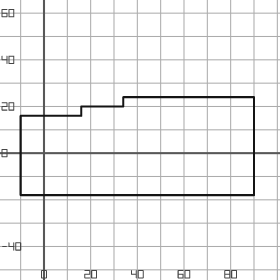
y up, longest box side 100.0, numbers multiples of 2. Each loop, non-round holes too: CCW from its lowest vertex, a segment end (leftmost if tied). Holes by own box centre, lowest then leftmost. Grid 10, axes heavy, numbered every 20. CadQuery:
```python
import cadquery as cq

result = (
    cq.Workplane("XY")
    .moveTo(-10.0, -18.0)
    .lineTo(90.0, -18.0)
    .lineTo(90.0, 24.0)
    .lineTo(34.0, 24.0)
    .lineTo(34.0, 20.0)
    .lineTo(16.0, 20.0)
    .lineTo(16.0, 16.0)
    .lineTo(-10.0, 16.0)
    .close()
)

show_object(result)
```